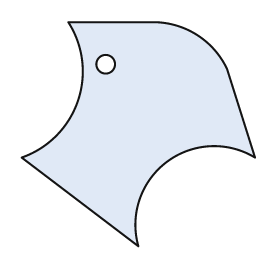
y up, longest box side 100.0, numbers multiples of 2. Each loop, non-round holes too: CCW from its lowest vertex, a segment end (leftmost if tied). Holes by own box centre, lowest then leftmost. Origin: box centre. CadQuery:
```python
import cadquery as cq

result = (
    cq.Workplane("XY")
    .moveTo(0.0, -48.0)
    .threePointArc((12.0, -12.0), (50.0, -10.0))
    .lineTo(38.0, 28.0)
    .threePointArc((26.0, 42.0), (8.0, 48.0))
    .lineTo(-30.0, 48.0)
    .threePointArc((-26.0, 14.0), (-50.0, -10.0))
    .close()
    .moveTo(-14.0, 30.0)
    .circle(4.0)
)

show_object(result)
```